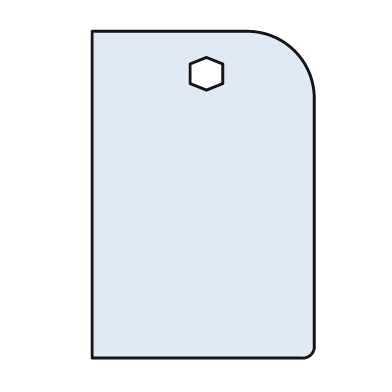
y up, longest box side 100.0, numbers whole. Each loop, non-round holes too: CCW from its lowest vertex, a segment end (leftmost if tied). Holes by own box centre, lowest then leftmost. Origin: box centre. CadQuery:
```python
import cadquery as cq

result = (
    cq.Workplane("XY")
    .moveTo(-34.0, -50.0)
    .lineTo(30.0, -50.0)
    .threePointArc((33.0, -49.0), (34.0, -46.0))
    .lineTo(34.0, 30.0)
    .threePointArc((28.0, 44.0), (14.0, 50.0))
    .lineTo(-34.0, 50.0)
    .close()
    .moveTo(1.0, 32.0)
    .lineTo(6.0, 34.0)
    .lineTo(6.0, 40.0)
    .lineTo(1.0, 42.0)
    .lineTo(-4.0, 40.0)
    .lineTo(-4.0, 34.0)
    .close()
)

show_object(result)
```